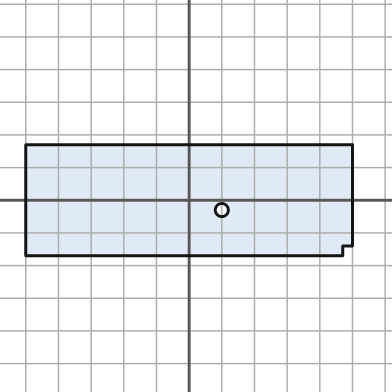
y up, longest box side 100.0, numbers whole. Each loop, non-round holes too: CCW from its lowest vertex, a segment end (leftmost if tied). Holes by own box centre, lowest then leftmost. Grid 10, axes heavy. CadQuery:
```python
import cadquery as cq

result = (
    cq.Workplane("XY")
    .moveTo(-50.0, -17.0)
    .lineTo(47.0, -17.0)
    .lineTo(47.0, -14.0)
    .lineTo(50.0, -14.0)
    .lineTo(50.0, 17.0)
    .lineTo(-50.0, 17.0)
    .close()
    .moveTo(10.0, -3.0)
    .circle(2.0)
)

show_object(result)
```